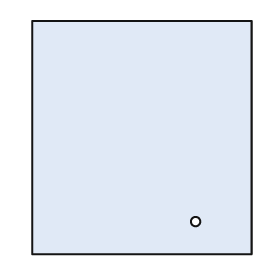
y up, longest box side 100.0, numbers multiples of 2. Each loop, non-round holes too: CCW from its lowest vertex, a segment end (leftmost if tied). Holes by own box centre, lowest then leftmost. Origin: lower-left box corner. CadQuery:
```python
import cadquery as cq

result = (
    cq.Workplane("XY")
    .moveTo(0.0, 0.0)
    .lineTo(94.0, 0.0)
    .lineTo(94.0, 100.0)
    .lineTo(0.0, 100.0)
    .close()
    .moveTo(70.0, 14.0)
    .circle(2.0)
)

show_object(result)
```